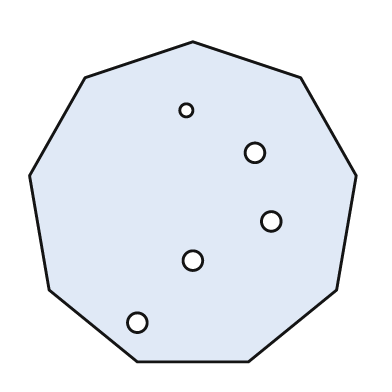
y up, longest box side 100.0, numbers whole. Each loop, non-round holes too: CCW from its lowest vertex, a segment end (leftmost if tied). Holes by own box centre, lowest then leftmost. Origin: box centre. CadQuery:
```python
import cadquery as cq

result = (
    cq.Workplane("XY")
    .moveTo(-17.0, -49.0)
    .lineTo(17.0, -49.0)
    .lineTo(44.0, -27.0)
    .lineTo(50.0, 8.0)
    .lineTo(33.0, 38.0)
    .lineTo(0.0, 49.0)
    .lineTo(-33.0, 38.0)
    .lineTo(-50.0, 8.0)
    .lineTo(-44.0, -27.0)
    .close()
    .moveTo(-17.0, -37.0)
    .circle(3.0)
    .moveTo(0.0, -18.0)
    .circle(3.0)
    .moveTo(24.0, -6.0)
    .circle(3.0)
    .moveTo(19.0, 15.0)
    .circle(3.0)
    .moveTo(-2.0, 28.0)
    .circle(2.0)
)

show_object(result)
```